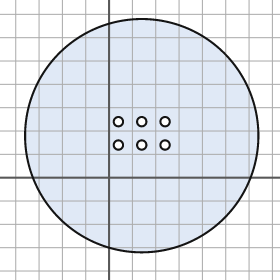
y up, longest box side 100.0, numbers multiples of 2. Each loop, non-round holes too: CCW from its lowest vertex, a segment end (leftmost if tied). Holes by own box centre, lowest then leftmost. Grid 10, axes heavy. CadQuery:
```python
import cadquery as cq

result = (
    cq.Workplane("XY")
    .moveTo(14.0, 18.0)
    .circle(50.0)
    .moveTo(4.0, 14.0)
    .circle(2.0)
    .moveTo(14.0, 14.0)
    .circle(2.0)
    .moveTo(24.0, 14.0)
    .circle(2.0)
    .moveTo(4.0, 24.0)
    .circle(2.0)
    .moveTo(14.0, 24.0)
    .circle(2.0)
    .moveTo(24.0, 24.0)
    .circle(2.0)
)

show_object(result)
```